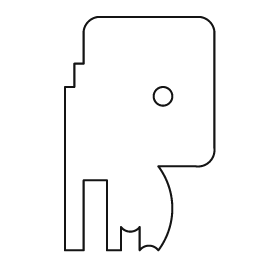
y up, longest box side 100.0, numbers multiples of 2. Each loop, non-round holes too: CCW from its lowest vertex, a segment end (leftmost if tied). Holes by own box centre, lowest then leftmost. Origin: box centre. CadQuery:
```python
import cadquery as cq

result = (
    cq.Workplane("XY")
    .moveTo(-32.0, -50.0)
    .lineTo(-24.0, -50.0)
    .lineTo(-24.0, -20.0)
    .lineTo(-14.0, -20.0)
    .lineTo(-14.0, -50.0)
    .lineTo(-8.0, -50.0)
    .lineTo(-8.0, -40.0)
    .threePointArc((-4.0, -42.0), (0.0, -40.0))
    .lineTo(0.0, -50.0)
    .threePointArc((4.0, -48.0), (8.0, -50.0))
    .threePointArc((14.0, -32.0), (8.0, -14.0))
    .lineTo(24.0, -14.0)
    .threePointArc((30.0, -12.0), (32.0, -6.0))
    .lineTo(32.0, 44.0)
    .threePointArc((30.0, 48.0), (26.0, 50.0))
    .lineTo(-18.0, 50.0)
    .threePointArc((-22.0, 48.0), (-24.0, 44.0))
    .lineTo(-24.0, 30.0)
    .lineTo(-28.0, 30.0)
    .lineTo(-28.0, 20.0)
    .lineTo(-32.0, 20.0)
    .close()
    .moveTo(10.0, 16.0)
    .circle(4.0)
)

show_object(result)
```